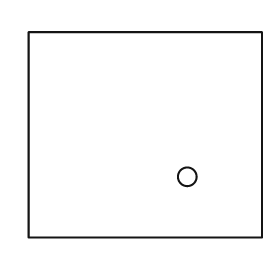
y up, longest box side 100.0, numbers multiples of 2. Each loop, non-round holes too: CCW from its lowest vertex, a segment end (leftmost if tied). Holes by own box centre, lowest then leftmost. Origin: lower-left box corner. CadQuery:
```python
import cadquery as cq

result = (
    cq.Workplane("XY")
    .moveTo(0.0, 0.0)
    .lineTo(100.0, 0.0)
    .lineTo(100.0, 88.0)
    .lineTo(0.0, 88.0)
    .close()
    .moveTo(68.0, 26.0)
    .circle(4.0)
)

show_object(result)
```